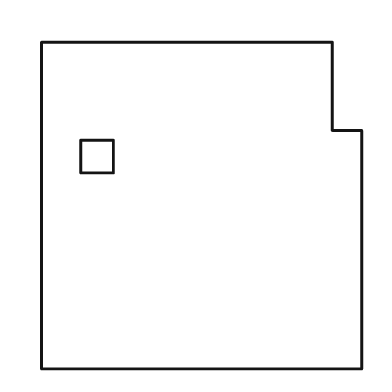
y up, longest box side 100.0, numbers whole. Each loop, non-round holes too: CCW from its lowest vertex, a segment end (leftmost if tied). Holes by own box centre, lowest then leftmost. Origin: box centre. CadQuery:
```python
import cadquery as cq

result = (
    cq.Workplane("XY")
    .moveTo(-49.0, -50.0)
    .lineTo(49.0, -50.0)
    .lineTo(49.0, 23.0)
    .lineTo(40.0, 23.0)
    .lineTo(40.0, 50.0)
    .lineTo(-49.0, 50.0)
    .close()
    .moveTo(-37.0, 10.0)
    .lineTo(-27.0, 10.0)
    .lineTo(-27.0, 20.0)
    .lineTo(-37.0, 20.0)
    .close()
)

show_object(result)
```